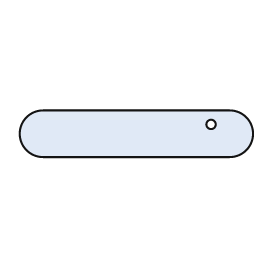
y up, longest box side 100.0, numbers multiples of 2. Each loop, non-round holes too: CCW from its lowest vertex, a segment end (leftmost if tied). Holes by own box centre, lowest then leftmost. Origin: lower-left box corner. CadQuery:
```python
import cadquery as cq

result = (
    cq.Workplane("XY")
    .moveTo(10.0, 0.0)
    .lineTo(90.0, 0.0)
    .threePointArc((100.0, 10.0), (90.0, 20.0))
    .lineTo(10.0, 20.0)
    .threePointArc((0.0, 10.0), (10.0, 0.0))
    .close()
    .moveTo(82.0, 14.0)
    .circle(2.0)
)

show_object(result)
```